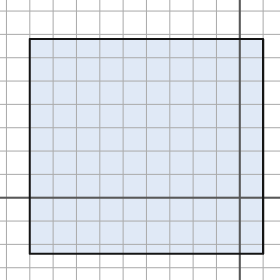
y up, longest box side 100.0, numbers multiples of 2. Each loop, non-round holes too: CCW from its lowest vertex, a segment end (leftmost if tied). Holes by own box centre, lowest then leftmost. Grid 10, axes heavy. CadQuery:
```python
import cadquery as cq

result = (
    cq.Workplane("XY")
    .moveTo(-90.0, -24.0)
    .lineTo(10.0, -24.0)
    .lineTo(10.0, 68.0)
    .lineTo(-90.0, 68.0)
    .close()
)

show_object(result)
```